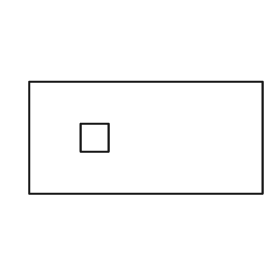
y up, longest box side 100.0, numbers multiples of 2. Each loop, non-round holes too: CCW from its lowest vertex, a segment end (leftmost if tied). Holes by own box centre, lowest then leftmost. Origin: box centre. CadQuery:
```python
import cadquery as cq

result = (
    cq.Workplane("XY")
    .moveTo(-50.0, -24.0)
    .lineTo(50.0, -24.0)
    .lineTo(50.0, 24.0)
    .lineTo(-50.0, 24.0)
    .close()
    .moveTo(-28.0, -6.0)
    .lineTo(-16.0, -6.0)
    .lineTo(-16.0, 6.0)
    .lineTo(-28.0, 6.0)
    .close()
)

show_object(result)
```